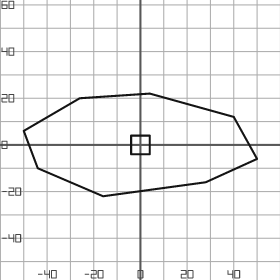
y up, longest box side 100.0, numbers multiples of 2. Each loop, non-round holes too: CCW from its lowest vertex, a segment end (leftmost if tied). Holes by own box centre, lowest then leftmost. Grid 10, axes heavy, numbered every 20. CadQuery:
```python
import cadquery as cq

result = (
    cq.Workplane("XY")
    .moveTo(-16.0, -22.0)
    .lineTo(28.0, -16.0)
    .lineTo(50.0, -6.0)
    .lineTo(40.0, 12.0)
    .lineTo(4.0, 22.0)
    .lineTo(-26.0, 20.0)
    .lineTo(-50.0, 6.0)
    .lineTo(-44.0, -10.0)
    .close()
    .moveTo(-4.0, -4.0)
    .lineTo(4.0, -4.0)
    .lineTo(4.0, 4.0)
    .lineTo(-4.0, 4.0)
    .close()
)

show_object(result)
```